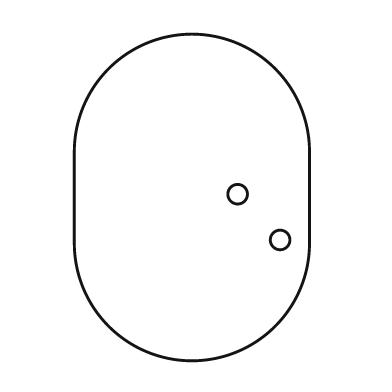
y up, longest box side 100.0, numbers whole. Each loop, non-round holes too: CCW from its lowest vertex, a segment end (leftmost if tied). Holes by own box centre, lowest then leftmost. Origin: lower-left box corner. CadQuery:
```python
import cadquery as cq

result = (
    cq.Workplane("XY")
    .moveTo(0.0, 36.0)
    .threePointArc((36.0, 0.0), (72.0, 36.0))
    .lineTo(72.0, 64.0)
    .threePointArc((36.0, 100.0), (0.0, 64.0))
    .close()
    .moveTo(63.0, 37.0)
    .circle(3.0)
    .moveTo(50.0, 51.0)
    .circle(3.0)
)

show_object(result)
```